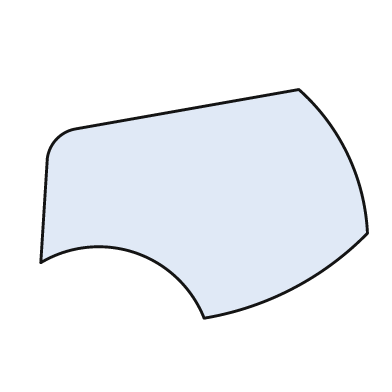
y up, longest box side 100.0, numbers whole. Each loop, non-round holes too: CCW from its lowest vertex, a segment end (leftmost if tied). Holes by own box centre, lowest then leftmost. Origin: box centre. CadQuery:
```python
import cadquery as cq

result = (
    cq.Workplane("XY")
    .moveTo(0.0, -35.0)
    .threePointArc((27.0, -26.0), (50.0, -9.0))
    .threePointArc((44.0, 15.0), (29.0, 35.0))
    .lineTo(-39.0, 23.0)
    .threePointArc((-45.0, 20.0), (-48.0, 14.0))
    .lineTo(-50.0, -18.0)
    .threePointArc((-21.0, -15.0), (0.0, -35.0))
    .close()
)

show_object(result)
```